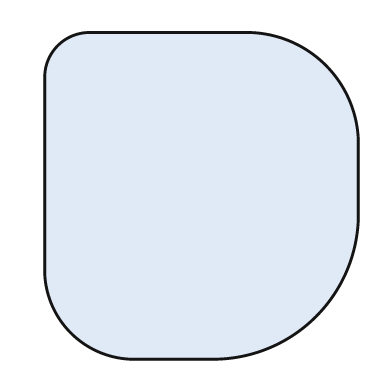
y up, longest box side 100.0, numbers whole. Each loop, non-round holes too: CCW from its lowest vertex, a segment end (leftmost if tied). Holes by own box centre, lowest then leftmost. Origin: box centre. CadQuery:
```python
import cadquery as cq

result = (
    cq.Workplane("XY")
    .moveTo(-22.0, -50.0)
    .lineTo(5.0, -50.0)
    .threePointArc((35.0, -37.0), (48.0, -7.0))
    .lineTo(48.0, 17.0)
    .threePointArc((38.0, 40.0), (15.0, 50.0))
    .lineTo(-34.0, 50.0)
    .threePointArc((-44.0, 46.0), (-48.0, 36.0))
    .lineTo(-48.0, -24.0)
    .threePointArc((-40.0, -42.0), (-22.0, -50.0))
    .close()
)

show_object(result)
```